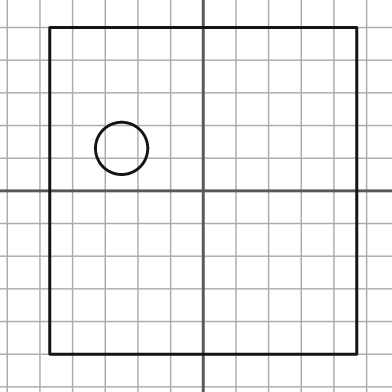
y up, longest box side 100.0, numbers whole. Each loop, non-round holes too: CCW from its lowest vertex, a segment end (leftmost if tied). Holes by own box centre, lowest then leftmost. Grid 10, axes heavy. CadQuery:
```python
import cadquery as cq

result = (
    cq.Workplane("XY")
    .moveTo(-47.0, -50.0)
    .lineTo(47.0, -50.0)
    .lineTo(47.0, 50.0)
    .lineTo(-47.0, 50.0)
    .close()
    .moveTo(-25.0, 13.0)
    .circle(8.0)
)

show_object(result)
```